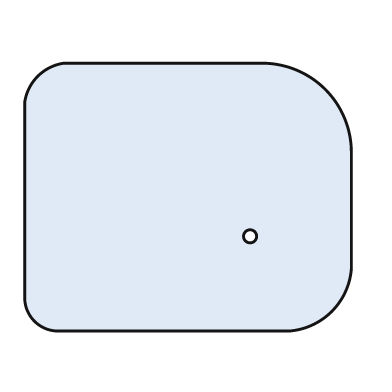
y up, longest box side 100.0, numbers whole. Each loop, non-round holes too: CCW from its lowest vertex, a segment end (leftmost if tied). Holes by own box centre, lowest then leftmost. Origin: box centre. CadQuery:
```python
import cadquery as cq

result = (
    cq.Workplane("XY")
    .moveTo(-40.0, -41.0)
    .lineTo(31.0, -41.0)
    .threePointArc((44.0, -35.0), (50.0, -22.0))
    .lineTo(50.0, 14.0)
    .threePointArc((42.0, 33.0), (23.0, 41.0))
    .lineTo(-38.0, 41.0)
    .threePointArc((-46.0, 37.0), (-50.0, 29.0))
    .lineTo(-50.0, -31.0)
    .threePointArc((-47.0, -38.0), (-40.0, -41.0))
    .close()
    .moveTo(19.0, -12.0)
    .circle(2.0)
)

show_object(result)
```